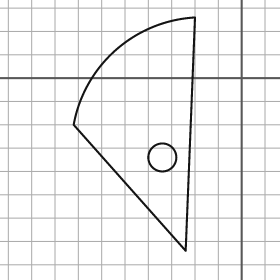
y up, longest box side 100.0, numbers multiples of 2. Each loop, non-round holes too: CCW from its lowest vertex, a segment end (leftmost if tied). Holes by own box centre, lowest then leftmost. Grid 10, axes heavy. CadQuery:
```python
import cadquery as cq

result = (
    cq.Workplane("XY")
    .moveTo(-24.0, -74.0)
    .lineTo(-20.0, 26.0)
    .threePointArc((-54.0, 12.0), (-72.0, -20.0))
    .close()
    .moveTo(-34.0, -34.0)
    .circle(6.0)
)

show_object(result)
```